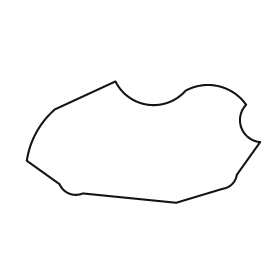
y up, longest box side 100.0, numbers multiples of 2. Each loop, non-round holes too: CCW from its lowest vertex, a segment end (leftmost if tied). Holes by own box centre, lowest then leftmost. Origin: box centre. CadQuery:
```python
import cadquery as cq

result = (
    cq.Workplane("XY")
    .moveTo(14.0, -26.0)
    .lineTo(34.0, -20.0)
    .threePointArc((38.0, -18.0), (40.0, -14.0))
    .lineTo(50.0, 0.0)
    .threePointArc((42.0, 6.0), (44.0, 16.0))
    .threePointArc((32.0, 24.0), (18.0, 22.0))
    .threePointArc((2.0, 16.0), (-12.0, 26.0))
    .lineTo(-38.0, 14.0)
    .threePointArc((-46.0, 4.0), (-50.0, -8.0))
    .lineTo(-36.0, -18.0)
    .threePointArc((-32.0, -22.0), (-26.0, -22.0))
    .close()
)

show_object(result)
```